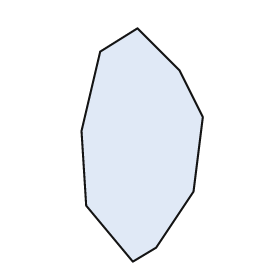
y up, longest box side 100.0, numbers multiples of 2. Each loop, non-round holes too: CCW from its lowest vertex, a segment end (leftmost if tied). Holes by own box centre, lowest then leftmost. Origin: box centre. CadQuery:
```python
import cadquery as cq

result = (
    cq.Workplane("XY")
    .moveTo(-4.0, -50.0)
    .lineTo(6.0, -44.0)
    .lineTo(22.0, -20.0)
    .lineTo(26.0, 12.0)
    .lineTo(16.0, 32.0)
    .lineTo(-2.0, 50.0)
    .lineTo(-18.0, 40.0)
    .lineTo(-26.0, 6.0)
    .lineTo(-24.0, -26.0)
    .close()
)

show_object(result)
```